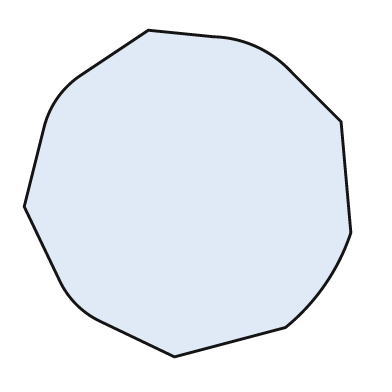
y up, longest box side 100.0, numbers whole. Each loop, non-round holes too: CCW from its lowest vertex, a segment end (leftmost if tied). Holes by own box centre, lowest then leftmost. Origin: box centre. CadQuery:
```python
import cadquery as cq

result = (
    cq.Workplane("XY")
    .moveTo(-4.0, -50.0)
    .lineTo(30.0, -41.0)
    .threePointArc((42.0, -28.0), (50.0, -12.0))
    .lineTo(47.0, 22.0)
    .lineTo(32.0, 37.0)
    .threePointArc((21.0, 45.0), (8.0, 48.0))
    .lineTo(-12.0, 50.0)
    .lineTo(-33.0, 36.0)
    .threePointArc((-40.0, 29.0), (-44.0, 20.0))
    .lineTo(-50.0, -4.0)
    .lineTo(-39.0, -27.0)
    .threePointArc((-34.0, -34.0), (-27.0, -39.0))
    .close()
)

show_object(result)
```